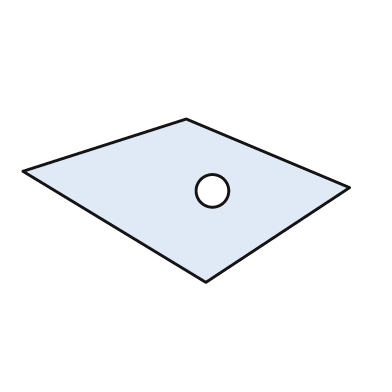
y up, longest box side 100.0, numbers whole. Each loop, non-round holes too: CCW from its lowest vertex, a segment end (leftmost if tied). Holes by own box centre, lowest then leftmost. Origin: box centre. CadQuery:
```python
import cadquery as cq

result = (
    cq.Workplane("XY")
    .moveTo(6.0, -25.0)
    .lineTo(50.0, 4.0)
    .lineTo(0.0, 25.0)
    .lineTo(-50.0, 9.0)
    .close()
    .moveTo(8.0, 3.0)
    .circle(5.0)
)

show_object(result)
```